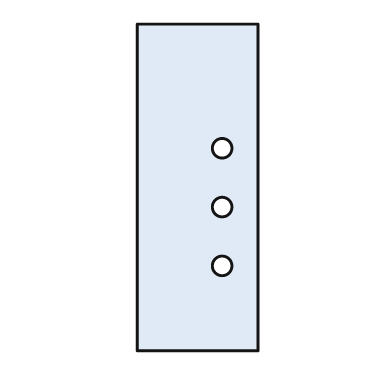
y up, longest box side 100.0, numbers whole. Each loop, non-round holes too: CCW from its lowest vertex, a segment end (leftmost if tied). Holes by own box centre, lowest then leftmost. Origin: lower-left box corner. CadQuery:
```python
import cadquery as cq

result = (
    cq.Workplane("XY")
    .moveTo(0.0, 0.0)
    .lineTo(37.0, 0.0)
    .lineTo(37.0, 100.0)
    .lineTo(0.0, 100.0)
    .close()
    .moveTo(26.0, 26.0)
    .circle(3.0)
    .moveTo(26.0, 44.0)
    .circle(3.0)
    .moveTo(26.0, 62.0)
    .circle(3.0)
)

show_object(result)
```